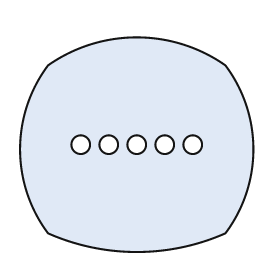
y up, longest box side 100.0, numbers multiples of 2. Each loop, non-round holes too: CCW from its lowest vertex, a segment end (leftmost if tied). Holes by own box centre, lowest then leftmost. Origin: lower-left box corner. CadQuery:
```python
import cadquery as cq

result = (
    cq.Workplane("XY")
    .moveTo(12.0, 8.0)
    .threePointArc((50.0, 0.0), (88.0, 8.0))
    .threePointArc((100.0, 44.0), (88.0, 80.0))
    .threePointArc((50.0, 92.0), (12.0, 80.0))
    .threePointArc((0.0, 44.0), (12.0, 8.0))
    .close()
    .moveTo(26.0, 46.0)
    .circle(4.0)
    .moveTo(38.0, 46.0)
    .circle(4.0)
    .moveTo(50.0, 46.0)
    .circle(4.0)
    .moveTo(62.0, 46.0)
    .circle(4.0)
    .moveTo(74.0, 46.0)
    .circle(4.0)
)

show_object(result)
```